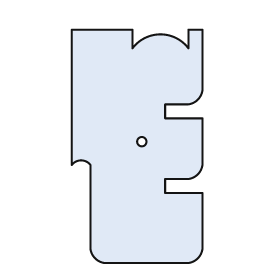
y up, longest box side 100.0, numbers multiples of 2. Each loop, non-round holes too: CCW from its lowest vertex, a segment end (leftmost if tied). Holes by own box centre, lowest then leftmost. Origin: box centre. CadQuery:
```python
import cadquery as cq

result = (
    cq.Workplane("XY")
    .moveTo(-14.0, -50.0)
    .lineTo(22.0, -50.0)
    .threePointArc((26.0, -48.0), (28.0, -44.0))
    .lineTo(28.0, -20.0)
    .lineTo(12.0, -20.0)
    .lineTo(12.0, -14.0)
    .lineTo(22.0, -14.0)
    .threePointArc((26.0, -12.0), (28.0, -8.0))
    .lineTo(28.0, 12.0)
    .lineTo(12.0, 12.0)
    .lineTo(12.0, 18.0)
    .lineTo(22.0, 18.0)
    .threePointArc((26.0, 20.0), (28.0, 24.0))
    .lineTo(28.0, 50.0)
    .lineTo(22.0, 50.0)
    .lineTo(22.0, 42.0)
    .threePointArc((10.0, 48.0), (-2.0, 42.0))
    .lineTo(-2.0, 50.0)
    .lineTo(-28.0, 50.0)
    .lineTo(-28.0, -8.0)
    .threePointArc((-24.0, -6.0), (-20.0, -8.0))
    .lineTo(-20.0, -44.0)
    .threePointArc((-18.0, -48.0), (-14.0, -50.0))
    .close()
    .moveTo(2.0, 2.0)
    .circle(2.0)
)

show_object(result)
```